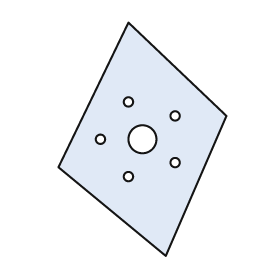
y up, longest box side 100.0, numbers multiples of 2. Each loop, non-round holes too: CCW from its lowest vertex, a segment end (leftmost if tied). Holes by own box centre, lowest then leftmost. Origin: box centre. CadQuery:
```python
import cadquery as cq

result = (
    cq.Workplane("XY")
    .moveTo(10.0, -50.0)
    .lineTo(36.0, 10.0)
    .lineTo(-6.0, 50.0)
    .lineTo(-36.0, -12.0)
    .close()
    .moveTo(-6.0, -16.0)
    .circle(2.0)
    .moveTo(14.0, -10.0)
    .circle(2.0)
    .moveTo(-18.0, 0.0)
    .circle(2.0)
    .moveTo(0.0, 0.0)
    .circle(6.0)
    .moveTo(14.0, 10.0)
    .circle(2.0)
    .moveTo(-6.0, 16.0)
    .circle(2.0)
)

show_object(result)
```